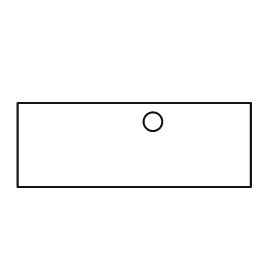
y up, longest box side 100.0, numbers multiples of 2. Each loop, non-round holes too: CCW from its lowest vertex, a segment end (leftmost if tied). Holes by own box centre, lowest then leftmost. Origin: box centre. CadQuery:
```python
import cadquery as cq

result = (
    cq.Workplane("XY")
    .moveTo(-50.0, -18.0)
    .lineTo(50.0, -18.0)
    .lineTo(50.0, 18.0)
    .lineTo(-50.0, 18.0)
    .close()
    .moveTo(8.0, 10.0)
    .circle(4.0)
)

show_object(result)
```